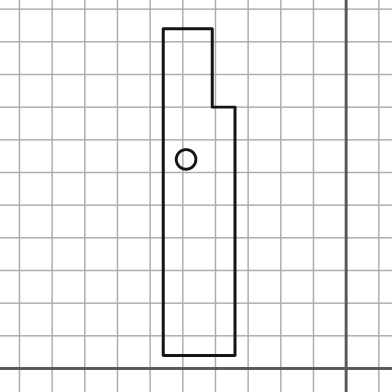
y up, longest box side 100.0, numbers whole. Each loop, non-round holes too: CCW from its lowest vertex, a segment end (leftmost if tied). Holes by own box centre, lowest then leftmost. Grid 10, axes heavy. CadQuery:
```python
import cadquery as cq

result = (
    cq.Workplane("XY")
    .moveTo(-56.0, 4.0)
    .lineTo(-34.0, 4.0)
    .lineTo(-34.0, 80.0)
    .lineTo(-41.0, 80.0)
    .lineTo(-41.0, 104.0)
    .lineTo(-56.0, 104.0)
    .close()
    .moveTo(-49.0, 64.0)
    .circle(3.0)
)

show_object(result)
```